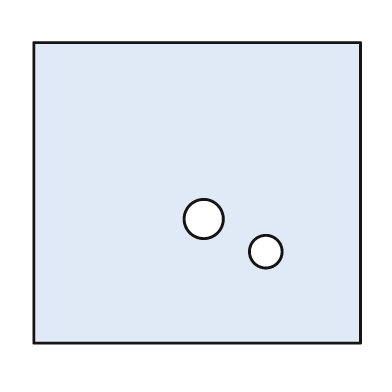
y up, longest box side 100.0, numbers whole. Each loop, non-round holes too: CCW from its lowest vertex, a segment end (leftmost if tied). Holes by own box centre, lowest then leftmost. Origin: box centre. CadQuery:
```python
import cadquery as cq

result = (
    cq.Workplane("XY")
    .moveTo(-50.0, -46.0)
    .lineTo(50.0, -46.0)
    .lineTo(50.0, 46.0)
    .lineTo(-50.0, 46.0)
    .close()
    .moveTo(21.0, -18.0)
    .circle(5.0)
    .moveTo(2.0, -8.0)
    .circle(6.0)
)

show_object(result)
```